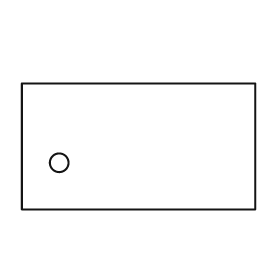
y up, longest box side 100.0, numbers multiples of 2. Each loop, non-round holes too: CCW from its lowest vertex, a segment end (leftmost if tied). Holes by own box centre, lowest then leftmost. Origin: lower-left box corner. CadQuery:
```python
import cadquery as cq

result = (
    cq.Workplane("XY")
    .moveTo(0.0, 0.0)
    .lineTo(100.0, 0.0)
    .lineTo(100.0, 54.0)
    .lineTo(0.0, 54.0)
    .close()
    .moveTo(16.0, 20.0)
    .circle(4.0)
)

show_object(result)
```